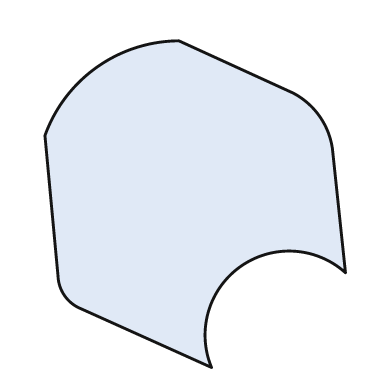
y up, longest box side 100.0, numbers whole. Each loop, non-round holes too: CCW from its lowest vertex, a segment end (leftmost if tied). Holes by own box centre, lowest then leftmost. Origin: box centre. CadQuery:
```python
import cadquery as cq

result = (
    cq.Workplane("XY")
    .moveTo(5.0, -50.0)
    .threePointArc((14.0, -19.0), (46.0, -21.0))
    .lineTo(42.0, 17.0)
    .threePointArc((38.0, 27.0), (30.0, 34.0))
    .lineTo(-5.0, 50.0)
    .threePointArc((-30.0, 42.0), (-46.0, 21.0))
    .lineTo(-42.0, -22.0)
    .threePointArc((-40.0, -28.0), (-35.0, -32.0))
    .close()
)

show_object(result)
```